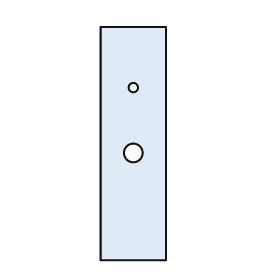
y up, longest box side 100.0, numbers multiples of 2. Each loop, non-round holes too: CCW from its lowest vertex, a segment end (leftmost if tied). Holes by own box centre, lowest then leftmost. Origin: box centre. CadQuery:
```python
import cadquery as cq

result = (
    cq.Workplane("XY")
    .moveTo(-14.0, -50.0)
    .lineTo(14.0, -50.0)
    .lineTo(14.0, 50.0)
    .lineTo(-14.0, 50.0)
    .close()
    .moveTo(0.0, -4.0)
    .circle(4.0)
    .moveTo(0.0, 24.0)
    .circle(2.0)
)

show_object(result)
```